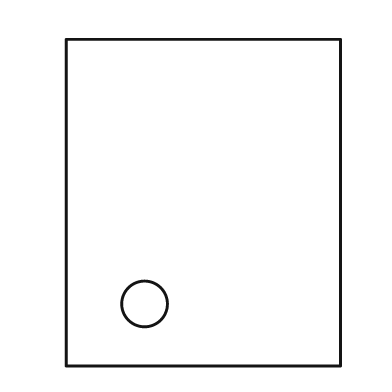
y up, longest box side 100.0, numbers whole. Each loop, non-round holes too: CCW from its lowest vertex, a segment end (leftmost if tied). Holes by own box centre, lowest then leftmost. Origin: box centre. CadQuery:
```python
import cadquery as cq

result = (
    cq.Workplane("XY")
    .moveTo(-42.0, -50.0)
    .lineTo(42.0, -50.0)
    .lineTo(42.0, 50.0)
    .lineTo(-42.0, 50.0)
    .close()
    .moveTo(-18.0, -31.0)
    .circle(7.0)
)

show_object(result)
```